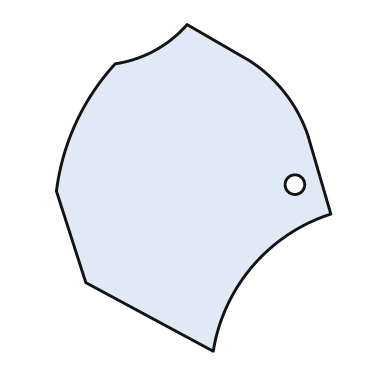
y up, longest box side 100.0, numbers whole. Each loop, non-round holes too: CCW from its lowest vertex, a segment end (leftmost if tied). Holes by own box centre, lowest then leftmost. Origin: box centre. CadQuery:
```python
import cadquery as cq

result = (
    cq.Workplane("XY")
    .moveTo(6.0, -50.0)
    .threePointArc((18.0, -24.0), (42.0, -8.0))
    .lineTo(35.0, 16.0)
    .threePointArc((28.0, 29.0), (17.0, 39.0))
    .lineTo(-2.0, 50.0)
    .threePointArc((-12.0, 42.0), (-24.0, 38.0))
    .threePointArc((-36.0, 20.0), (-42.0, -1.0))
    .lineTo(-33.0, -29.0)
    .close()
    .moveTo(31.0, 1.0)
    .circle(3.0)
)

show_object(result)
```